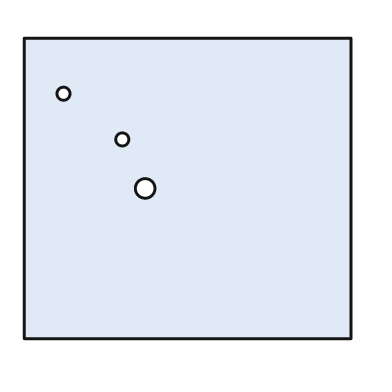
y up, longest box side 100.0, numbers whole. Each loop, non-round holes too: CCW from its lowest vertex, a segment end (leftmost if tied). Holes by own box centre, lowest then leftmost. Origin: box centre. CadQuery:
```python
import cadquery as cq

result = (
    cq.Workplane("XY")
    .moveTo(-50.0, -46.0)
    .lineTo(50.0, -46.0)
    .lineTo(50.0, 46.0)
    .lineTo(-50.0, 46.0)
    .close()
    .moveTo(-13.0, 0.0)
    .circle(3.0)
    .moveTo(-20.0, 15.0)
    .circle(2.0)
    .moveTo(-38.0, 29.0)
    .circle(2.0)
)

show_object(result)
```